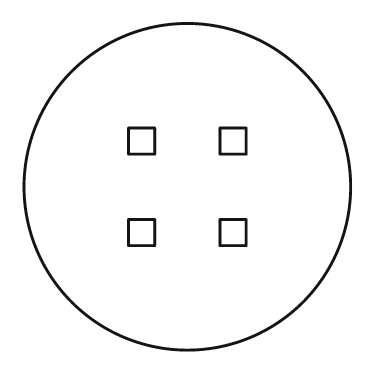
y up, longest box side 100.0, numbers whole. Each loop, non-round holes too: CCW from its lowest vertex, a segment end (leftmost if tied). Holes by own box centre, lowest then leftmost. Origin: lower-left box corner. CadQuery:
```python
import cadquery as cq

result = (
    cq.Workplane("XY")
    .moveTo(50.0, 50.0)
    .circle(50.0)
    .moveTo(32.0, 32.0)
    .lineTo(40.0, 32.0)
    .lineTo(40.0, 40.0)
    .lineTo(32.0, 40.0)
    .close()
    .moveTo(60.0, 32.0)
    .lineTo(68.0, 32.0)
    .lineTo(68.0, 40.0)
    .lineTo(60.0, 40.0)
    .close()
    .moveTo(32.0, 60.0)
    .lineTo(40.0, 60.0)
    .lineTo(40.0, 68.0)
    .lineTo(32.0, 68.0)
    .close()
    .moveTo(60.0, 60.0)
    .lineTo(68.0, 60.0)
    .lineTo(68.0, 68.0)
    .lineTo(60.0, 68.0)
    .close()
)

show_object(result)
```